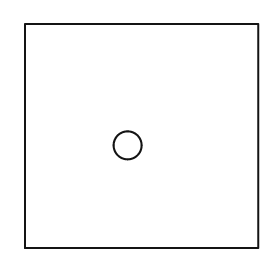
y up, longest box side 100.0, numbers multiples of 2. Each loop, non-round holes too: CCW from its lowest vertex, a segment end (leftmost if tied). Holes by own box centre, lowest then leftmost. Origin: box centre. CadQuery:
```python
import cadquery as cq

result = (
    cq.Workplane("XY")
    .moveTo(-50.0, -48.0)
    .lineTo(50.0, -48.0)
    .lineTo(50.0, 48.0)
    .lineTo(-50.0, 48.0)
    .close()
    .moveTo(-6.0, -4.0)
    .circle(6.0)
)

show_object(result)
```